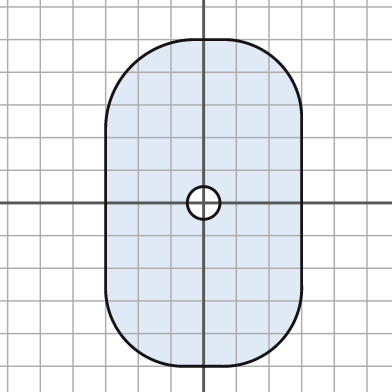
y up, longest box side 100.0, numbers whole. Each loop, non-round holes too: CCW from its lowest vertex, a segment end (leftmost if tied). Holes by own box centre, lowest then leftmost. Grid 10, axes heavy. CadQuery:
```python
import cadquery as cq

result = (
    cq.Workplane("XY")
    .moveTo(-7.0, -50.0)
    .lineTo(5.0, -50.0)
    .threePointArc((23.0, -43.0), (30.0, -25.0))
    .lineTo(30.0, 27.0)
    .threePointArc((23.0, 43.0), (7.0, 50.0))
    .lineTo(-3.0, 50.0)
    .threePointArc((-22.0, 42.0), (-30.0, 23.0))
    .lineTo(-30.0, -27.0)
    .threePointArc((-23.0, -43.0), (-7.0, -50.0))
    .close()
    .moveTo(0.0, 0.0)
    .circle(5.0)
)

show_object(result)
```